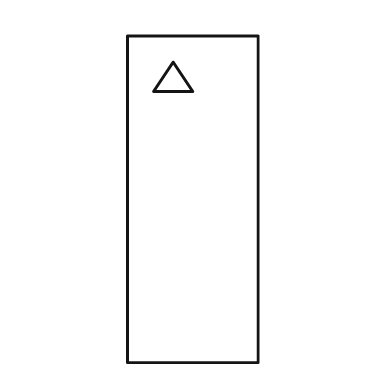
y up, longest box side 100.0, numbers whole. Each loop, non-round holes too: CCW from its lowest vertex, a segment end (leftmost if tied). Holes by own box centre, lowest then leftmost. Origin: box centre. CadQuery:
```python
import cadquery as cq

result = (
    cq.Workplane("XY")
    .moveTo(-20.0, -50.0)
    .lineTo(20.0, -50.0)
    .lineTo(20.0, 50.0)
    .lineTo(-20.0, 50.0)
    .close()
    .moveTo(-12.0, 33.0)
    .lineTo(0.0, 33.0)
    .lineTo(-6.0, 42.0)
    .close()
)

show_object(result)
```